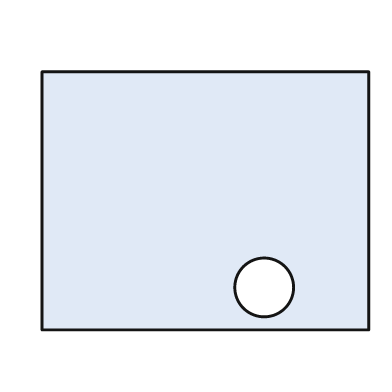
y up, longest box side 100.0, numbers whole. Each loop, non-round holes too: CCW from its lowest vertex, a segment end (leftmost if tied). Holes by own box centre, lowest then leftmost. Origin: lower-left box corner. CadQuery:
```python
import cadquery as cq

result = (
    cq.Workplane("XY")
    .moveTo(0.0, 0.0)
    .lineTo(100.0, 0.0)
    .lineTo(100.0, 79.0)
    .lineTo(0.0, 79.0)
    .close()
    .moveTo(68.0, 13.0)
    .circle(9.0)
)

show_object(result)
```